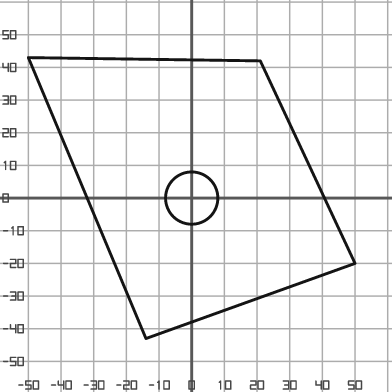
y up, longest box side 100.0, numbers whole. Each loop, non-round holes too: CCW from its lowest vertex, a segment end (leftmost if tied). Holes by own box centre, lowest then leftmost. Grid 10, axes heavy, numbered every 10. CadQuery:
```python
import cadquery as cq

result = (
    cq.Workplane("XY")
    .moveTo(-14.0, -43.0)
    .lineTo(50.0, -20.0)
    .lineTo(21.0, 42.0)
    .lineTo(-50.0, 43.0)
    .close()
    .moveTo(0.0, 0.0)
    .circle(8.0)
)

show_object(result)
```